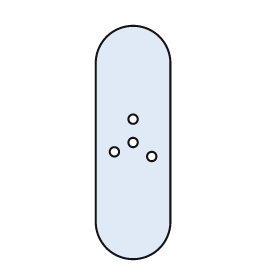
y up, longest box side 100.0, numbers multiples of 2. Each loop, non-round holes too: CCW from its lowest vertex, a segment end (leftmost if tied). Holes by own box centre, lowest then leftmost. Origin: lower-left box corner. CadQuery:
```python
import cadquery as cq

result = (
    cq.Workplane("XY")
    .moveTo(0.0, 16.0)
    .threePointArc((16.0, 0.0), (32.0, 16.0))
    .lineTo(32.0, 84.0)
    .threePointArc((16.0, 100.0), (0.0, 84.0))
    .close()
    .moveTo(24.0, 44.0)
    .circle(2.0)
    .moveTo(8.0, 46.0)
    .circle(2.0)
    .moveTo(16.0, 50.0)
    .circle(2.0)
    .moveTo(16.0, 60.0)
    .circle(2.0)
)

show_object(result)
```